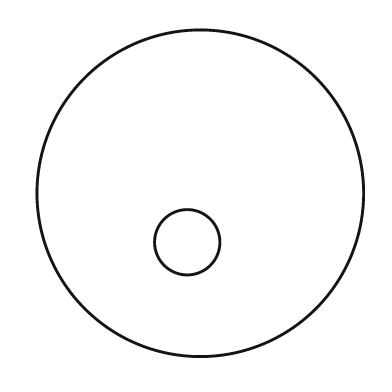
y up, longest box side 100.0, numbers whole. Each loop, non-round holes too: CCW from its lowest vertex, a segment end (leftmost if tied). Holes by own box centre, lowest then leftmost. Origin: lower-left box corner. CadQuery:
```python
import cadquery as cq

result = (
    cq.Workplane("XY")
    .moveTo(50.0, 50.0)
    .circle(50.0)
    .moveTo(46.0, 35.0)
    .circle(10.0)
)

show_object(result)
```